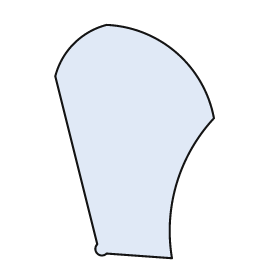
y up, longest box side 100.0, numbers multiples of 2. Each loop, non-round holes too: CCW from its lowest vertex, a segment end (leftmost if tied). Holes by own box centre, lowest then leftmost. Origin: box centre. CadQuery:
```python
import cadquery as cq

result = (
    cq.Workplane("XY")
    .moveTo(16.0, -50.0)
    .threePointArc((18.0, -18.0), (34.0, 10.0))
    .threePointArc((18.0, 38.0), (-12.0, 50.0))
    .threePointArc((-26.0, 42.0), (-34.0, 28.0))
    .lineTo(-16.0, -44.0)
    .threePointArc((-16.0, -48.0), (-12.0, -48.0))
    .close()
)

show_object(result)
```